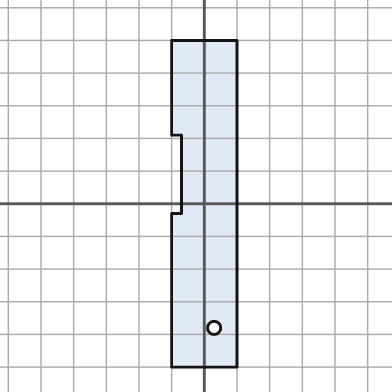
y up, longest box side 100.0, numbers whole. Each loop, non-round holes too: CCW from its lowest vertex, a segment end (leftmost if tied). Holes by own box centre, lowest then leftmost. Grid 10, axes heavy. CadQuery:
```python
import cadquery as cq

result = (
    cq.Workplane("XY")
    .moveTo(-10.0, -50.0)
    .lineTo(10.0, -50.0)
    .lineTo(10.0, 50.0)
    .lineTo(-10.0, 50.0)
    .lineTo(-10.0, 21.0)
    .lineTo(-7.0, 21.0)
    .lineTo(-7.0, -3.0)
    .lineTo(-10.0, -3.0)
    .close()
    .moveTo(3.0, -38.0)
    .circle(2.0)
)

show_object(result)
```